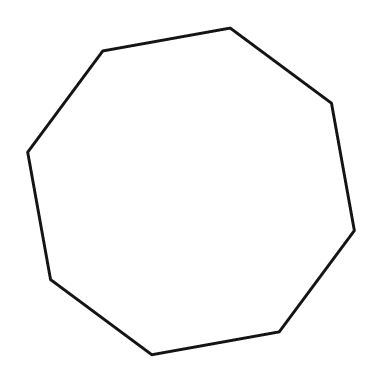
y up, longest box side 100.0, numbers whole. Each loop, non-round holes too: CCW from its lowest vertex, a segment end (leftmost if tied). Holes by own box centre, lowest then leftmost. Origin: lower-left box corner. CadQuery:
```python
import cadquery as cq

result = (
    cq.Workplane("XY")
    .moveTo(38.0, 0.0)
    .lineTo(77.0, 7.0)
    .lineTo(100.0, 38.0)
    .lineTo(93.0, 77.0)
    .lineTo(62.0, 100.0)
    .lineTo(23.0, 93.0)
    .lineTo(0.0, 62.0)
    .lineTo(7.0, 23.0)
    .close()
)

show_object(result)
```